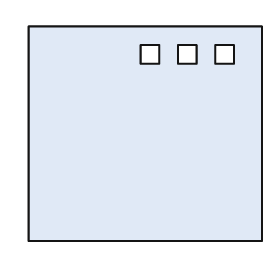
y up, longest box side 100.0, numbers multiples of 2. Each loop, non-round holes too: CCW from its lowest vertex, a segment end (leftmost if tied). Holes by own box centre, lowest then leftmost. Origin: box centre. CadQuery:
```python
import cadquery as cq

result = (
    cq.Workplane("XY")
    .moveTo(-50.0, -46.0)
    .lineTo(50.0, -46.0)
    .lineTo(50.0, 46.0)
    .lineTo(-50.0, 46.0)
    .close()
    .moveTo(-2.0, 30.0)
    .lineTo(6.0, 30.0)
    .lineTo(6.0, 38.0)
    .lineTo(-2.0, 38.0)
    .close()
    .moveTo(14.0, 30.0)
    .lineTo(22.0, 30.0)
    .lineTo(22.0, 38.0)
    .lineTo(14.0, 38.0)
    .close()
    .moveTo(30.0, 30.0)
    .lineTo(38.0, 30.0)
    .lineTo(38.0, 38.0)
    .lineTo(30.0, 38.0)
    .close()
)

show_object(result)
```